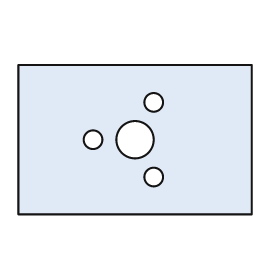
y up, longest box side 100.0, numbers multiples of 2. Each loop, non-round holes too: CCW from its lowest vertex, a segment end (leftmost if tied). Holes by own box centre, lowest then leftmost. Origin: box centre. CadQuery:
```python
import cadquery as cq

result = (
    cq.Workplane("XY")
    .moveTo(-50.0, -32.0)
    .lineTo(50.0, -32.0)
    .lineTo(50.0, 32.0)
    .lineTo(-50.0, 32.0)
    .close()
    .moveTo(8.0, -16.0)
    .circle(4.0)
    .moveTo(-18.0, 0.0)
    .circle(4.0)
    .moveTo(0.0, 0.0)
    .circle(8.0)
    .moveTo(8.0, 16.0)
    .circle(4.0)
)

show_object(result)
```